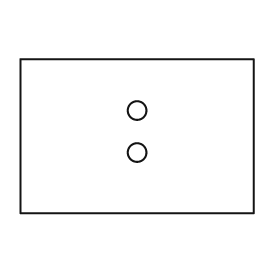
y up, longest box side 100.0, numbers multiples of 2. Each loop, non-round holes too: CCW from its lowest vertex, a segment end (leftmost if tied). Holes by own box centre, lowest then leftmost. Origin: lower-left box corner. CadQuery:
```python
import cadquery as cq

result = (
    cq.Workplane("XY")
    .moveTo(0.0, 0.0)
    .lineTo(100.0, 0.0)
    .lineTo(100.0, 66.0)
    .lineTo(0.0, 66.0)
    .close()
    .moveTo(50.0, 26.0)
    .circle(4.0)
    .moveTo(50.0, 44.0)
    .circle(4.0)
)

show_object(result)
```